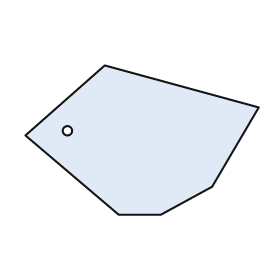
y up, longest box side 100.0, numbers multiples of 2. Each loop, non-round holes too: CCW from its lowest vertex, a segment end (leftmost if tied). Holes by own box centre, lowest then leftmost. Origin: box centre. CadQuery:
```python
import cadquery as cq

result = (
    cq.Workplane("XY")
    .moveTo(-10.0, -32.0)
    .lineTo(8.0, -32.0)
    .lineTo(30.0, -20.0)
    .lineTo(50.0, 14.0)
    .lineTo(-16.0, 32.0)
    .lineTo(-50.0, 2.0)
    .close()
    .moveTo(-32.0, 4.0)
    .circle(2.0)
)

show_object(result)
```